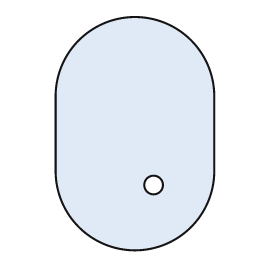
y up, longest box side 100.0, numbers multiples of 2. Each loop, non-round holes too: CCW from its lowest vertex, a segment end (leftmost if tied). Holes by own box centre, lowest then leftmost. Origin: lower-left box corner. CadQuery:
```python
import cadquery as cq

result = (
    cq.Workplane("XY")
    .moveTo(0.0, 34.0)
    .threePointArc((34.0, 0.0), (68.0, 34.0))
    .lineTo(68.0, 66.0)
    .threePointArc((34.0, 100.0), (0.0, 66.0))
    .close()
    .moveTo(42.0, 28.0)
    .circle(4.0)
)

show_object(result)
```